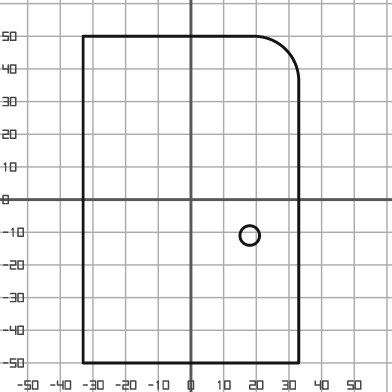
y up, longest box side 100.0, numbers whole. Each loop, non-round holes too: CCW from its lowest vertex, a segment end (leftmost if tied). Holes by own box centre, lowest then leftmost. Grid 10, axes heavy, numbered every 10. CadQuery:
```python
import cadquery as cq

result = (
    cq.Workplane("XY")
    .moveTo(-33.0, -50.0)
    .lineTo(33.0, -50.0)
    .lineTo(33.0, 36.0)
    .threePointArc((29.0, 46.0), (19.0, 50.0))
    .lineTo(-33.0, 50.0)
    .close()
    .moveTo(18.0, -11.0)
    .circle(3.0)
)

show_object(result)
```